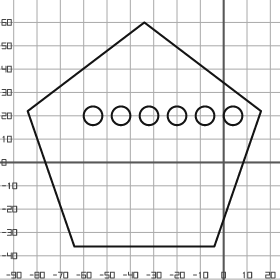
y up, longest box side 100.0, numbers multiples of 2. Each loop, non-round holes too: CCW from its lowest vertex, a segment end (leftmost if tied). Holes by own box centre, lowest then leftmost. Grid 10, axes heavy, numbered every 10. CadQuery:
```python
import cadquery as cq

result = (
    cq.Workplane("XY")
    .moveTo(-64.0, -36.0)
    .lineTo(-4.0, -36.0)
    .lineTo(16.0, 22.0)
    .lineTo(-34.0, 60.0)
    .lineTo(-84.0, 22.0)
    .close()
    .moveTo(-56.0, 20.0)
    .circle(4.0)
    .moveTo(-44.0, 20.0)
    .circle(4.0)
    .moveTo(-32.0, 20.0)
    .circle(4.0)
    .moveTo(-20.0, 20.0)
    .circle(4.0)
    .moveTo(-8.0, 20.0)
    .circle(4.0)
    .moveTo(4.0, 20.0)
    .circle(4.0)
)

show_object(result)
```